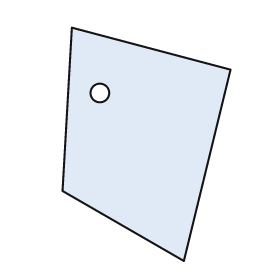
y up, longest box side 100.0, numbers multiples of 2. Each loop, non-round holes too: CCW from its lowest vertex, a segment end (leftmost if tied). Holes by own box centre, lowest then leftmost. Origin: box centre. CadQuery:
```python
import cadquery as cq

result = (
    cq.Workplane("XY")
    .moveTo(16.0, -50.0)
    .lineTo(36.0, 32.0)
    .lineTo(-32.0, 50.0)
    .lineTo(-36.0, -20.0)
    .close()
    .moveTo(-20.0, 22.0)
    .circle(4.0)
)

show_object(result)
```